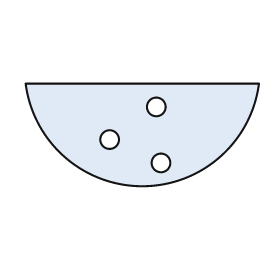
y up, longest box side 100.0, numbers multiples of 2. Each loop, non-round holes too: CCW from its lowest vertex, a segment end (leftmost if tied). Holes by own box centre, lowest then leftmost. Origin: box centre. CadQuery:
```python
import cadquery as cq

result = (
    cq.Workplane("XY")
    .moveTo(-50.0, 22.0)
    .threePointArc((0.0, -22.0), (50.0, 22.0))
    .close()
    .moveTo(8.0, -12.0)
    .circle(4.0)
    .moveTo(-14.0, -2.0)
    .circle(4.0)
    .moveTo(6.0, 12.0)
    .circle(4.0)
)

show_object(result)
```